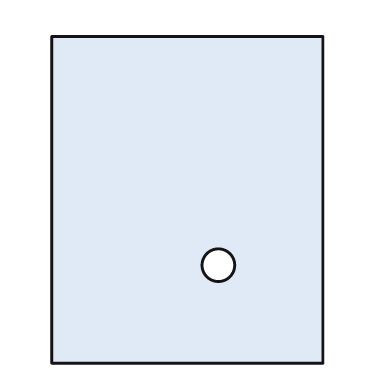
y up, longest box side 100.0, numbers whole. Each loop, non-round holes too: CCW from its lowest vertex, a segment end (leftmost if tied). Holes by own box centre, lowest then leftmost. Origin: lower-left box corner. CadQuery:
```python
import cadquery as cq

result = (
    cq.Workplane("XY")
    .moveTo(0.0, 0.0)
    .lineTo(83.0, 0.0)
    .lineTo(83.0, 100.0)
    .lineTo(0.0, 100.0)
    .close()
    .moveTo(51.0, 30.0)
    .circle(5.0)
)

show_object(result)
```